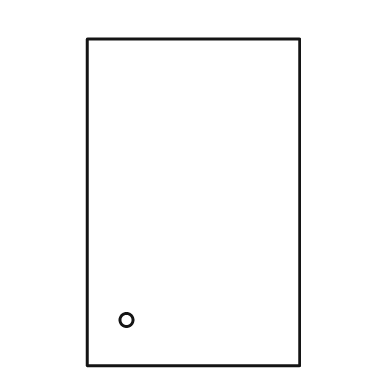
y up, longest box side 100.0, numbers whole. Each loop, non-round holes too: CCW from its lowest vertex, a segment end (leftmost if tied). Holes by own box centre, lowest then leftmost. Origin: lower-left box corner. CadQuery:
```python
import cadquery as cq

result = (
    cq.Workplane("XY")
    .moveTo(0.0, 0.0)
    .lineTo(65.0, 0.0)
    .lineTo(65.0, 100.0)
    .lineTo(0.0, 100.0)
    .close()
    .moveTo(12.0, 14.0)
    .circle(2.0)
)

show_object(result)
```